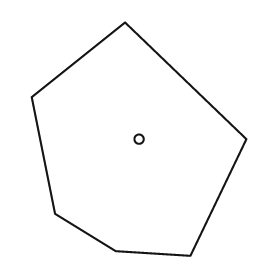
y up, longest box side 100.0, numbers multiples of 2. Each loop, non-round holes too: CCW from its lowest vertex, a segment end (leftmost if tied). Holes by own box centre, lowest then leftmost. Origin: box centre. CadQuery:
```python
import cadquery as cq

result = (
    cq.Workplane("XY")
    .moveTo(22.0, -50.0)
    .lineTo(46.0, 0.0)
    .lineTo(-6.0, 50.0)
    .lineTo(-46.0, 18.0)
    .lineTo(-36.0, -32.0)
    .lineTo(-10.0, -48.0)
    .close()
    .moveTo(0.0, 0.0)
    .circle(2.0)
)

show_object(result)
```